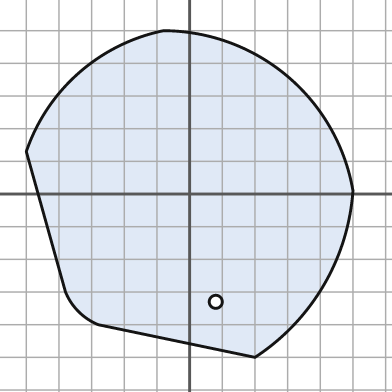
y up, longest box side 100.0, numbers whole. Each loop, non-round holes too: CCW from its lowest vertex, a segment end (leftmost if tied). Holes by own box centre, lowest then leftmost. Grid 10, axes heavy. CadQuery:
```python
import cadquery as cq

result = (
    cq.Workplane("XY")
    .moveTo(20.0, -50.0)
    .threePointArc((41.0, -28.0), (50.0, 1.0))
    .threePointArc((30.0, 36.0), (-8.0, 50.0))
    .threePointArc((-34.0, 37.0), (-50.0, 13.0))
    .lineTo(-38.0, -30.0)
    .threePointArc((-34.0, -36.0), (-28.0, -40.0))
    .close()
    .moveTo(8.0, -33.0)
    .circle(2.0)
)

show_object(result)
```